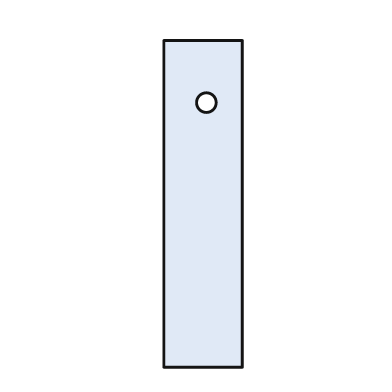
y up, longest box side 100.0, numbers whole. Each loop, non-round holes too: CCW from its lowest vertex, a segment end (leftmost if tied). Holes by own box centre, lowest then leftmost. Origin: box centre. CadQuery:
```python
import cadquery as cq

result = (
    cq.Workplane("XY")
    .moveTo(-12.0, -50.0)
    .lineTo(12.0, -50.0)
    .lineTo(12.0, 50.0)
    .lineTo(-12.0, 50.0)
    .close()
    .moveTo(1.0, 31.0)
    .circle(3.0)
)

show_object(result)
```